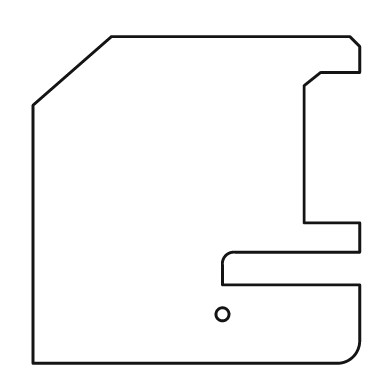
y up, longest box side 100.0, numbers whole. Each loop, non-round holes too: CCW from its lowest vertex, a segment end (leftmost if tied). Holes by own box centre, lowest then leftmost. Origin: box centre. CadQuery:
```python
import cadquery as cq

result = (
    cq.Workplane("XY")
    .moveTo(-50.0, -50.0)
    .lineTo(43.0, -50.0)
    .threePointArc((48.0, -48.0), (50.0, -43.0))
    .lineTo(50.0, -26.0)
    .lineTo(8.0, -26.0)
    .lineTo(8.0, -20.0)
    .threePointArc((9.0, -17.0), (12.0, -16.0))
    .lineTo(50.0, -16.0)
    .lineTo(50.0, -7.0)
    .lineTo(33.0, -7.0)
    .lineTo(33.0, 35.0)
    .lineTo(38.0, 39.0)
    .lineTo(50.0, 39.0)
    .lineTo(50.0, 47.0)
    .lineTo(47.0, 50.0)
    .lineTo(-26.0, 50.0)
    .lineTo(-50.0, 29.0)
    .close()
    .moveTo(8.0, -35.0)
    .circle(2.0)
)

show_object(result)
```